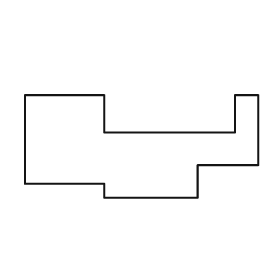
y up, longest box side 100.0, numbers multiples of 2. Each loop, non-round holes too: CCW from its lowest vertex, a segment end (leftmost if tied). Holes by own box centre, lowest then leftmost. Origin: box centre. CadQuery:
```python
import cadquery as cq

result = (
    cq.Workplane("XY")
    .moveTo(-16.0, -22.0)
    .lineTo(24.0, -22.0)
    .lineTo(24.0, -8.0)
    .lineTo(50.0, -8.0)
    .lineTo(50.0, 22.0)
    .lineTo(40.0, 22.0)
    .lineTo(40.0, 6.0)
    .lineTo(-16.0, 6.0)
    .lineTo(-16.0, 22.0)
    .lineTo(-50.0, 22.0)
    .lineTo(-50.0, -16.0)
    .lineTo(-16.0, -16.0)
    .close()
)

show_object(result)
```